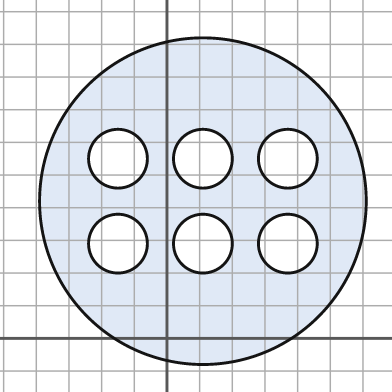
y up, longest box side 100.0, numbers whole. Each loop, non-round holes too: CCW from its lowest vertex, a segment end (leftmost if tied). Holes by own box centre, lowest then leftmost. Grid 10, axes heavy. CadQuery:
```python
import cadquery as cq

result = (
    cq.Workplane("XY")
    .moveTo(11.0, 42.0)
    .circle(50.0)
    .moveTo(-15.0, 29.0)
    .circle(9.0)
    .moveTo(11.0, 29.0)
    .circle(9.0)
    .moveTo(37.0, 29.0)
    .circle(9.0)
    .moveTo(-15.0, 55.0)
    .circle(9.0)
    .moveTo(11.0, 55.0)
    .circle(9.0)
    .moveTo(37.0, 55.0)
    .circle(9.0)
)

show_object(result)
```